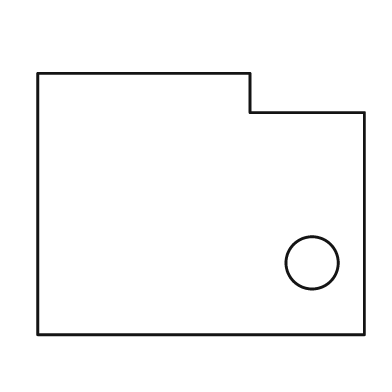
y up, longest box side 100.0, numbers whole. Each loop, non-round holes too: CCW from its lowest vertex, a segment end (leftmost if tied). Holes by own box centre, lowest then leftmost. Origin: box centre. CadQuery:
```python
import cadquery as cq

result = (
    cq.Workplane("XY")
    .moveTo(-50.0, -40.0)
    .lineTo(50.0, -40.0)
    .lineTo(50.0, 28.0)
    .lineTo(15.0, 28.0)
    .lineTo(15.0, 40.0)
    .lineTo(-50.0, 40.0)
    .close()
    .moveTo(34.0, -18.0)
    .circle(8.0)
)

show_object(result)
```